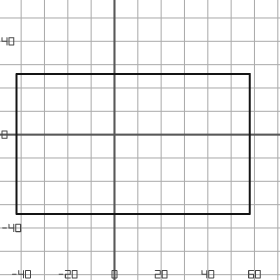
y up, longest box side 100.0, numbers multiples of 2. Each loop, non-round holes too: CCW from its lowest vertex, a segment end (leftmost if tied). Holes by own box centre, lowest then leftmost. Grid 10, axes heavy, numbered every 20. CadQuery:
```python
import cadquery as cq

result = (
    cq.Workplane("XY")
    .moveTo(-42.0, -34.0)
    .lineTo(58.0, -34.0)
    .lineTo(58.0, 26.0)
    .lineTo(-42.0, 26.0)
    .close()
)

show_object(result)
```